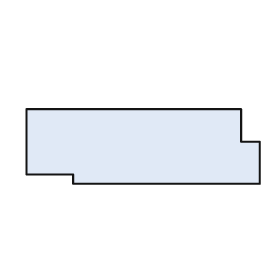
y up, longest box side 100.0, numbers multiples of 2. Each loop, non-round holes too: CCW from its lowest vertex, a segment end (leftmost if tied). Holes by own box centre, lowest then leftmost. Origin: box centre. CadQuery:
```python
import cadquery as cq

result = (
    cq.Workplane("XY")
    .moveTo(-30.0, -16.0)
    .lineTo(50.0, -16.0)
    .lineTo(50.0, 2.0)
    .lineTo(42.0, 2.0)
    .lineTo(42.0, 16.0)
    .lineTo(-50.0, 16.0)
    .lineTo(-50.0, -12.0)
    .lineTo(-30.0, -12.0)
    .close()
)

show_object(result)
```